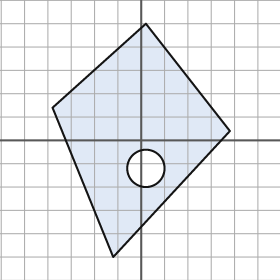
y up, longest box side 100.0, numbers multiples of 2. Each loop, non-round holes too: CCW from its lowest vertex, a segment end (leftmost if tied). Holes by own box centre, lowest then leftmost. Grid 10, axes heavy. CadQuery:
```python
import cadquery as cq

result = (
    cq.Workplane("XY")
    .moveTo(-12.0, -50.0)
    .lineTo(38.0, 4.0)
    .lineTo(2.0, 50.0)
    .lineTo(-38.0, 14.0)
    .close()
    .moveTo(2.0, -12.0)
    .circle(8.0)
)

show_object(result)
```